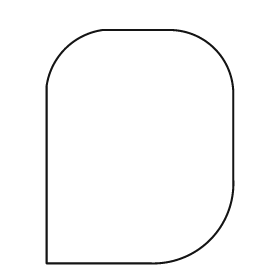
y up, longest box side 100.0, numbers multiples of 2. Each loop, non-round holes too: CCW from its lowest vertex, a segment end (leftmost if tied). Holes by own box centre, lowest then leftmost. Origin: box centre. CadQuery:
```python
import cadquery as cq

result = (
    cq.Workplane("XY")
    .moveTo(-40.0, -50.0)
    .lineTo(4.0, -50.0)
    .threePointArc((30.0, -40.0), (40.0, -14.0))
    .lineTo(40.0, 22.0)
    .threePointArc((32.0, 42.0), (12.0, 50.0))
    .lineTo(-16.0, 50.0)
    .threePointArc((-32.0, 42.0), (-40.0, 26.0))
    .close()
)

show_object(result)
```